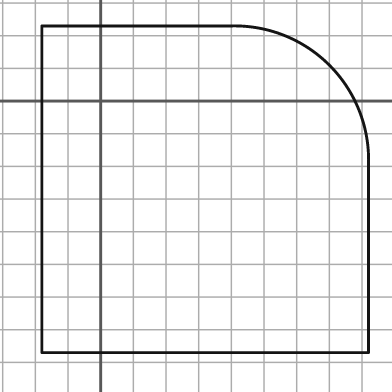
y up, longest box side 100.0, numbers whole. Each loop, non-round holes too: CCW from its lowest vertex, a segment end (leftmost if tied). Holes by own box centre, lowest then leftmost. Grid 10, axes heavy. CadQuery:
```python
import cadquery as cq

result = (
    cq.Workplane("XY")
    .moveTo(-18.0, -77.0)
    .lineTo(82.0, -77.0)
    .lineTo(82.0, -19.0)
    .threePointArc((70.0, 11.0), (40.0, 23.0))
    .lineTo(-18.0, 23.0)
    .close()
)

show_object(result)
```